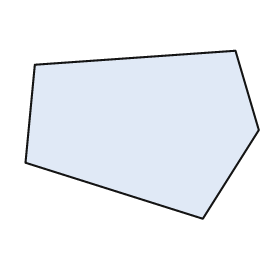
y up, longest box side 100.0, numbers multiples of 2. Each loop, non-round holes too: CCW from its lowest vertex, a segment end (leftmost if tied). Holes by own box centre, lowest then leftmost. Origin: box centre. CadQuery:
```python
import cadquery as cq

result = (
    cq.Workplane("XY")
    .moveTo(26.0, -36.0)
    .lineTo(50.0, 2.0)
    .lineTo(40.0, 36.0)
    .lineTo(-46.0, 30.0)
    .lineTo(-50.0, -12.0)
    .close()
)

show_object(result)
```